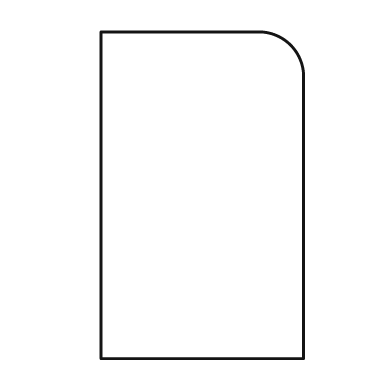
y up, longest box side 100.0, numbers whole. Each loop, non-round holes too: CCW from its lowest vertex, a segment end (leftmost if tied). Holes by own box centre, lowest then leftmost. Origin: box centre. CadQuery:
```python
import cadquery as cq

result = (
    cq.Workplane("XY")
    .moveTo(-31.0, -50.0)
    .lineTo(31.0, -50.0)
    .lineTo(31.0, 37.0)
    .threePointArc((27.0, 46.0), (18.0, 50.0))
    .lineTo(-31.0, 50.0)
    .close()
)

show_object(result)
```